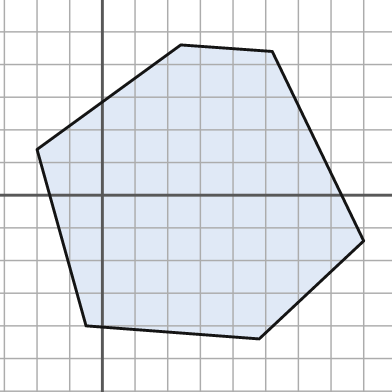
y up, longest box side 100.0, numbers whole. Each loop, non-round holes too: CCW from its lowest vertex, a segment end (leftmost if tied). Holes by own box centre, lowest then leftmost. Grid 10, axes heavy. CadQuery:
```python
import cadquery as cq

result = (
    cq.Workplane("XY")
    .moveTo(48.0, -44.0)
    .lineTo(80.0, -14.0)
    .lineTo(52.0, 44.0)
    .lineTo(24.0, 46.0)
    .lineTo(-20.0, 14.0)
    .lineTo(-5.0, -40.0)
    .close()
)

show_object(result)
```